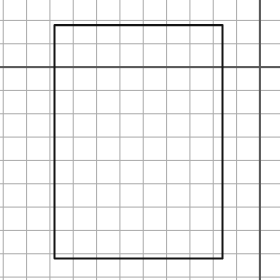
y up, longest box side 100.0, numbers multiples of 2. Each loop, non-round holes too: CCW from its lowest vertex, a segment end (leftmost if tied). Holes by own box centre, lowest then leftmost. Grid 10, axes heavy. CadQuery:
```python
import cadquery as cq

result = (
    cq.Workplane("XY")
    .moveTo(-88.0, -82.0)
    .lineTo(-16.0, -82.0)
    .lineTo(-16.0, 18.0)
    .lineTo(-88.0, 18.0)
    .close()
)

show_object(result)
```